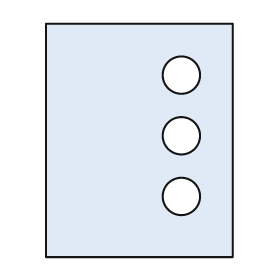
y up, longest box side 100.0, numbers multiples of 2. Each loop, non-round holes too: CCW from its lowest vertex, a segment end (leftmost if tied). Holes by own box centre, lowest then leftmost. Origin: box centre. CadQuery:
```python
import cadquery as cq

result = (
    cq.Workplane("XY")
    .moveTo(-40.0, -50.0)
    .lineTo(40.0, -50.0)
    .lineTo(40.0, 50.0)
    .lineTo(-40.0, 50.0)
    .close()
    .moveTo(18.0, -24.0)
    .circle(8.0)
    .moveTo(18.0, 2.0)
    .circle(8.0)
    .moveTo(18.0, 28.0)
    .circle(8.0)
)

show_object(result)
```